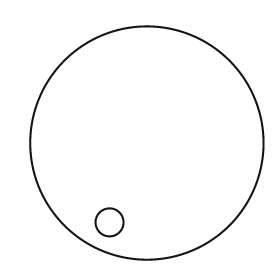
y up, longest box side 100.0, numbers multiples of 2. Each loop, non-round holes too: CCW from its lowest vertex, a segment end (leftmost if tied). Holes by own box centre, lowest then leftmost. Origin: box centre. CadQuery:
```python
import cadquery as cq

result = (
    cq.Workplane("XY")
    .moveTo(0.0, 0.0)
    .circle(50.0)
    .moveTo(-16.0, -34.0)
    .circle(6.0)
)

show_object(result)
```